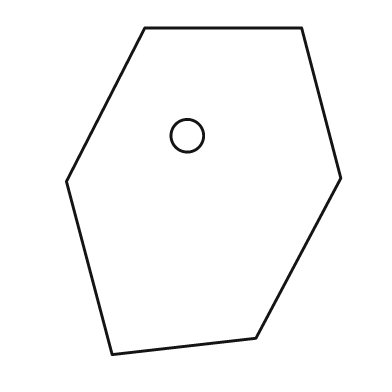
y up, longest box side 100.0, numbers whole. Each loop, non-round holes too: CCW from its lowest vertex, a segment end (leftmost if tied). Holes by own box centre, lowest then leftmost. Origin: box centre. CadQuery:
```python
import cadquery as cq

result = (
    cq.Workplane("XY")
    .moveTo(-28.0, -50.0)
    .lineTo(16.0, -45.0)
    .lineTo(42.0, 4.0)
    .lineTo(30.0, 50.0)
    .lineTo(-18.0, 50.0)
    .lineTo(-42.0, 3.0)
    .close()
    .moveTo(-5.0, 17.0)
    .circle(5.0)
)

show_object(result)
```